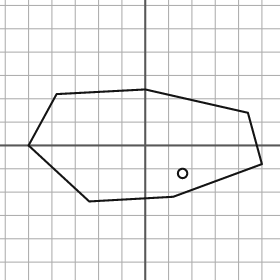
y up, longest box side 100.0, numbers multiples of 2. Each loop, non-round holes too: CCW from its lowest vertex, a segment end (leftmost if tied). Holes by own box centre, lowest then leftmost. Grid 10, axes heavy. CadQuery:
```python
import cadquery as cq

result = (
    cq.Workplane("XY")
    .moveTo(-24.0, -24.0)
    .lineTo(12.0, -22.0)
    .lineTo(50.0, -8.0)
    .lineTo(44.0, 14.0)
    .lineTo(0.0, 24.0)
    .lineTo(-38.0, 22.0)
    .lineTo(-50.0, 0.0)
    .close()
    .moveTo(16.0, -12.0)
    .circle(2.0)
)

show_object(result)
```